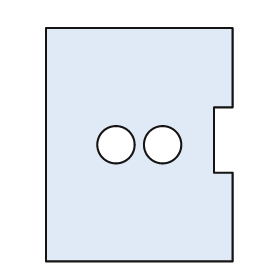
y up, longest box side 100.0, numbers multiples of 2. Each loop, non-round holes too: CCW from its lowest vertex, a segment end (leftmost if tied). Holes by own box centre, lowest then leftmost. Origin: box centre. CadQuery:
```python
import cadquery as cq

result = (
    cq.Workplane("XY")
    .moveTo(-40.0, -50.0)
    .lineTo(40.0, -50.0)
    .lineTo(40.0, -12.0)
    .lineTo(32.0, -12.0)
    .lineTo(32.0, 16.0)
    .lineTo(40.0, 16.0)
    .lineTo(40.0, 50.0)
    .lineTo(-40.0, 50.0)
    .close()
    .moveTo(-10.0, 0.0)
    .circle(8.0)
    .moveTo(10.0, 0.0)
    .circle(8.0)
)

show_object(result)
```